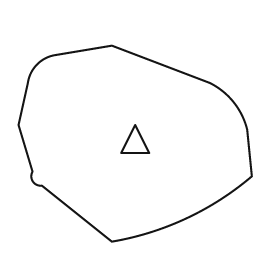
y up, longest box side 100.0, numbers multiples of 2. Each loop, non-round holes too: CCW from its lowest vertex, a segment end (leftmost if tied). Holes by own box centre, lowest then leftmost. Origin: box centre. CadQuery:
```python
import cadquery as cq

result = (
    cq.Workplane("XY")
    .moveTo(-10.0, -42.0)
    .threePointArc((22.0, -32.0), (50.0, -14.0))
    .lineTo(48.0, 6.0)
    .threePointArc((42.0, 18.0), (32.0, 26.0))
    .lineTo(-10.0, 42.0)
    .lineTo(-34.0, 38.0)
    .threePointArc((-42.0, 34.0), (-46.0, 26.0))
    .lineTo(-50.0, 8.0)
    .lineTo(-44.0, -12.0)
    .threePointArc((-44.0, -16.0), (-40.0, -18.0))
    .close()
    .moveTo(-6.0, -4.0)
    .lineTo(6.0, -4.0)
    .lineTo(0.0, 8.0)
    .close()
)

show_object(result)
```